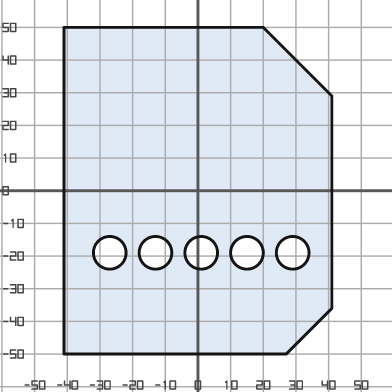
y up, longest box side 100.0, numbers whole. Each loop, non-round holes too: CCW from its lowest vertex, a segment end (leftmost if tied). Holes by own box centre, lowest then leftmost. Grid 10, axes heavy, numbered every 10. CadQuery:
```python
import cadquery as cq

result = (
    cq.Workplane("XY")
    .moveTo(-41.0, -50.0)
    .lineTo(27.0, -50.0)
    .lineTo(41.0, -36.0)
    .lineTo(41.0, 29.0)
    .lineTo(20.0, 50.0)
    .lineTo(-41.0, 50.0)
    .close()
    .moveTo(-27.0, -19.0)
    .circle(5.0)
    .moveTo(-13.0, -19.0)
    .circle(5.0)
    .moveTo(1.0, -19.0)
    .circle(5.0)
    .moveTo(15.0, -19.0)
    .circle(5.0)
    .moveTo(29.0, -19.0)
    .circle(5.0)
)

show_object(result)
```